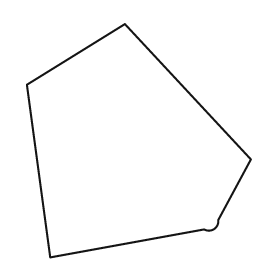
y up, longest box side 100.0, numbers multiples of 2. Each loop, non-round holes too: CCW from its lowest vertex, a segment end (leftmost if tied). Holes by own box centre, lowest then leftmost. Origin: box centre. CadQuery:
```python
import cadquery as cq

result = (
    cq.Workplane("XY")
    .moveTo(-38.0, -50.0)
    .lineTo(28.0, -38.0)
    .threePointArc((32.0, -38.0), (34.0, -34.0))
    .lineTo(48.0, -8.0)
    .lineTo(-6.0, 50.0)
    .lineTo(-48.0, 24.0)
    .close()
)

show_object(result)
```